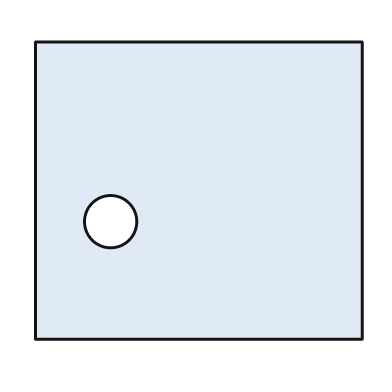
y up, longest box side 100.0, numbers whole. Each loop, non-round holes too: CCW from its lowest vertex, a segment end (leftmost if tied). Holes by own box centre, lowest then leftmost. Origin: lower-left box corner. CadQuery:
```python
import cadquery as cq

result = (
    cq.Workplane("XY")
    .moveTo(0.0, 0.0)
    .lineTo(100.0, 0.0)
    .lineTo(100.0, 91.0)
    .lineTo(0.0, 91.0)
    .close()
    .moveTo(23.0, 36.0)
    .circle(8.0)
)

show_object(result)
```